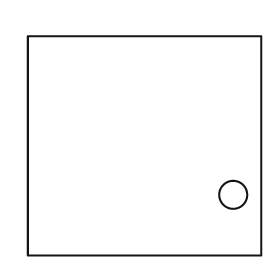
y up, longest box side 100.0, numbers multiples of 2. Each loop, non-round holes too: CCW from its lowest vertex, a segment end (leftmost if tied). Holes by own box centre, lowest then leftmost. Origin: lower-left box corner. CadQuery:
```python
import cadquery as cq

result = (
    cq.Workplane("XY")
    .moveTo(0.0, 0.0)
    .lineTo(100.0, 0.0)
    .lineTo(100.0, 94.0)
    .lineTo(0.0, 94.0)
    .close()
    .moveTo(88.0, 26.0)
    .circle(6.0)
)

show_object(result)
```